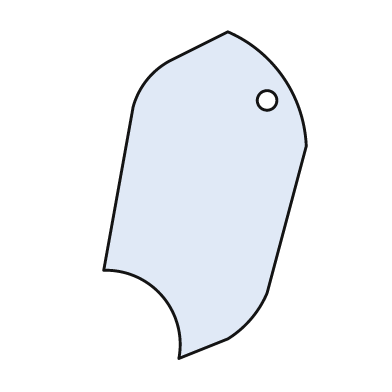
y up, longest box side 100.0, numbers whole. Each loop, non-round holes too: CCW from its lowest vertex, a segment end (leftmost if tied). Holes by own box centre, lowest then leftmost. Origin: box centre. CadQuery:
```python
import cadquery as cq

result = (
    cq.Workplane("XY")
    .moveTo(-8.0, -50.0)
    .lineTo(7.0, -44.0)
    .threePointArc((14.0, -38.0), (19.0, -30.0))
    .lineTo(31.0, 15.0)
    .threePointArc((24.0, 36.0), (7.0, 50.0))
    .lineTo(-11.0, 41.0)
    .threePointArc((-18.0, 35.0), (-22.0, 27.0))
    .lineTo(-31.0, -23.0)
    .threePointArc((-13.0, -31.0), (-8.0, -50.0))
    .close()
    .moveTo(19.0, 29.0)
    .circle(3.0)
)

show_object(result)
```